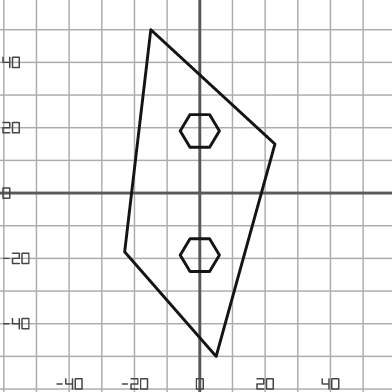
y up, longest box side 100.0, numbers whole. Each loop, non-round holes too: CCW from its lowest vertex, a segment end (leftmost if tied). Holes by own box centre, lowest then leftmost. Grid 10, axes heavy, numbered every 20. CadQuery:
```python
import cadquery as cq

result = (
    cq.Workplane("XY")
    .moveTo(5.0, -50.0)
    .lineTo(23.0, 15.0)
    .lineTo(-15.0, 50.0)
    .lineTo(-23.0, -18.0)
    .close()
    .moveTo(-3.0, -24.0)
    .lineTo(3.0, -24.0)
    .lineTo(6.0, -19.0)
    .lineTo(3.0, -14.0)
    .lineTo(-3.0, -14.0)
    .lineTo(-6.0, -19.0)
    .close()
    .moveTo(-3.0, 14.0)
    .lineTo(3.0, 14.0)
    .lineTo(6.0, 19.0)
    .lineTo(3.0, 24.0)
    .lineTo(-3.0, 24.0)
    .lineTo(-6.0, 19.0)
    .close()
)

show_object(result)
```